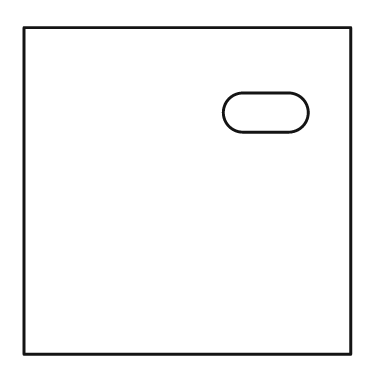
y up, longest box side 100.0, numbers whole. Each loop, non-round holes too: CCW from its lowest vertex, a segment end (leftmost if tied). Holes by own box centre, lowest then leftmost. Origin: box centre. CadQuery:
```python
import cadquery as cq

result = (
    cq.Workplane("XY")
    .moveTo(-50.0, -50.0)
    .lineTo(50.0, -50.0)
    .lineTo(50.0, 50.0)
    .lineTo(-50.0, 50.0)
    .close()
    .moveTo(17.0, 18.0)
    .lineTo(31.0, 18.0)
    .threePointArc((37.0, 24.0), (31.0, 30.0))
    .lineTo(17.0, 30.0)
    .threePointArc((11.0, 24.0), (17.0, 18.0))
    .close()
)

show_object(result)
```